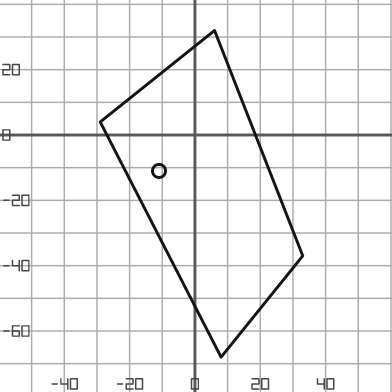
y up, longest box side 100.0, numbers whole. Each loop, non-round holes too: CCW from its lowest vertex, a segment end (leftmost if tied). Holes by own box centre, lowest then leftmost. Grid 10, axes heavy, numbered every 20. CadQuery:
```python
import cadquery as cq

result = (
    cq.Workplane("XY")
    .moveTo(8.0, -68.0)
    .lineTo(33.0, -37.0)
    .lineTo(6.0, 32.0)
    .lineTo(-29.0, 4.0)
    .close()
    .moveTo(-11.0, -11.0)
    .circle(2.0)
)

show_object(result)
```